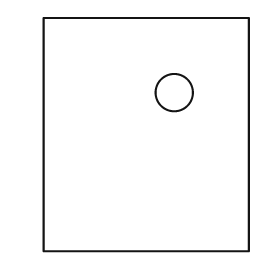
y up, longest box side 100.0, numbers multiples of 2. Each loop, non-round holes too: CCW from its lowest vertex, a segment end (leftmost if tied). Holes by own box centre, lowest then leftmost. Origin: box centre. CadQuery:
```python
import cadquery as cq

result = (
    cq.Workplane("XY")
    .moveTo(-44.0, -50.0)
    .lineTo(44.0, -50.0)
    .lineTo(44.0, 50.0)
    .lineTo(-44.0, 50.0)
    .close()
    .moveTo(12.0, 18.0)
    .circle(8.0)
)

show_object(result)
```